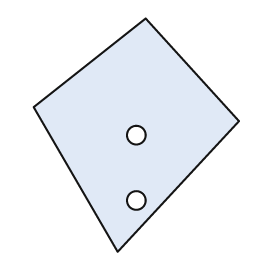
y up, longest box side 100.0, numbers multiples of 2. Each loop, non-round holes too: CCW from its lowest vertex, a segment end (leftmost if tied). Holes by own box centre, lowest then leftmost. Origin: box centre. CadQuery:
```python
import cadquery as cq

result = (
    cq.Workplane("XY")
    .moveTo(-8.0, -50.0)
    .lineTo(44.0, 6.0)
    .lineTo(4.0, 50.0)
    .lineTo(-44.0, 12.0)
    .close()
    .moveTo(0.0, -28.0)
    .circle(4.0)
    .moveTo(0.0, 0.0)
    .circle(4.0)
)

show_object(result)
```